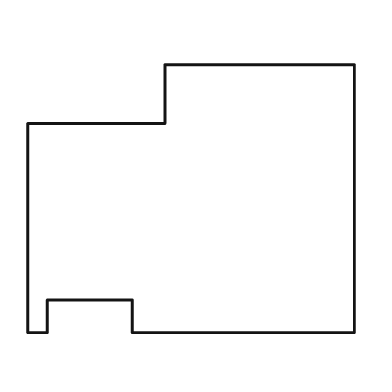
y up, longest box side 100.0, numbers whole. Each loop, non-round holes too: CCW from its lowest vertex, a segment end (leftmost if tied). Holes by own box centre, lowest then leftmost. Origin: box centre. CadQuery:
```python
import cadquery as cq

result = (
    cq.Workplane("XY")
    .moveTo(-50.0, -41.0)
    .lineTo(-44.0, -41.0)
    .lineTo(-44.0, -31.0)
    .lineTo(-18.0, -31.0)
    .lineTo(-18.0, -41.0)
    .lineTo(50.0, -41.0)
    .lineTo(50.0, 41.0)
    .lineTo(-8.0, 41.0)
    .lineTo(-8.0, 23.0)
    .lineTo(-50.0, 23.0)
    .close()
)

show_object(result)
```